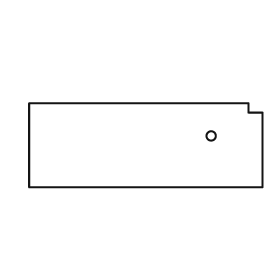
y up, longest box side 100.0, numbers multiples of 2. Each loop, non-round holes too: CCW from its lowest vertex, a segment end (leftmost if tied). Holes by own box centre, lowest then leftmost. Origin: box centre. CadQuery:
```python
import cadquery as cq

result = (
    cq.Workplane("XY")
    .moveTo(-50.0, -18.0)
    .lineTo(50.0, -18.0)
    .lineTo(50.0, 14.0)
    .lineTo(44.0, 14.0)
    .lineTo(44.0, 18.0)
    .lineTo(-50.0, 18.0)
    .close()
    .moveTo(28.0, 4.0)
    .circle(2.0)
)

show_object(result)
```